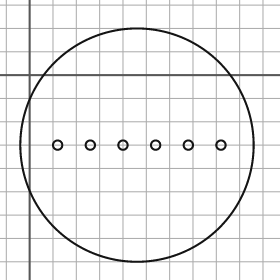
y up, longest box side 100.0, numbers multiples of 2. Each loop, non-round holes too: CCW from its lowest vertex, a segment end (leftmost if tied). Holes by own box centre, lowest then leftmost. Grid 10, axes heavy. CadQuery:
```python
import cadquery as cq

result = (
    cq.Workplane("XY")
    .moveTo(46.0, -30.0)
    .circle(50.0)
    .moveTo(12.0, -30.0)
    .circle(2.0)
    .moveTo(26.0, -30.0)
    .circle(2.0)
    .moveTo(40.0, -30.0)
    .circle(2.0)
    .moveTo(54.0, -30.0)
    .circle(2.0)
    .moveTo(68.0, -30.0)
    .circle(2.0)
    .moveTo(82.0, -30.0)
    .circle(2.0)
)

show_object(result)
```